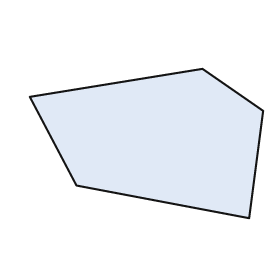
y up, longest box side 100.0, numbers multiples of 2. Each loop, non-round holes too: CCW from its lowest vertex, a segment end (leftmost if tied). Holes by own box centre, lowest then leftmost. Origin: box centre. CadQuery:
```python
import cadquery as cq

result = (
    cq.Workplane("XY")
    .moveTo(44.0, -32.0)
    .lineTo(50.0, 14.0)
    .lineTo(24.0, 32.0)
    .lineTo(-50.0, 20.0)
    .lineTo(-30.0, -18.0)
    .close()
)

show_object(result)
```